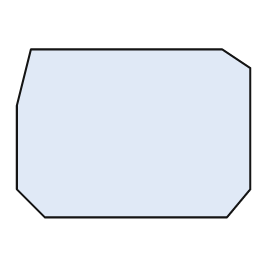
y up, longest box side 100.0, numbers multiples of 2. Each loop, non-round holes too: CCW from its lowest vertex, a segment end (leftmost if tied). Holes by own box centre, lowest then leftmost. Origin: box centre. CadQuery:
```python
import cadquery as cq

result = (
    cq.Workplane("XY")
    .moveTo(-38.0, -36.0)
    .lineTo(40.0, -36.0)
    .lineTo(50.0, -24.0)
    .lineTo(50.0, 28.0)
    .lineTo(38.0, 36.0)
    .lineTo(-44.0, 36.0)
    .lineTo(-50.0, 12.0)
    .lineTo(-50.0, -24.0)
    .close()
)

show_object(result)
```